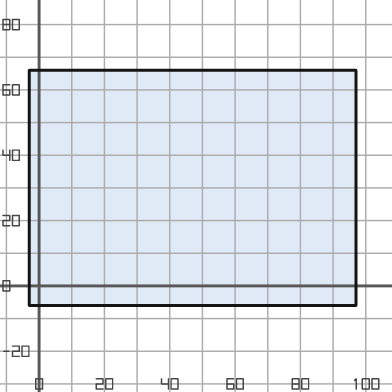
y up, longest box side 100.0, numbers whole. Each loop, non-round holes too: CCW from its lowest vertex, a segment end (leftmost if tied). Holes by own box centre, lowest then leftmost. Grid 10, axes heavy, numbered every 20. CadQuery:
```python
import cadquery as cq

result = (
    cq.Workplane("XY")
    .moveTo(-3.0, -6.0)
    .lineTo(97.0, -6.0)
    .lineTo(97.0, 66.0)
    .lineTo(-3.0, 66.0)
    .close()
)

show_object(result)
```